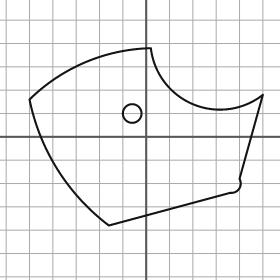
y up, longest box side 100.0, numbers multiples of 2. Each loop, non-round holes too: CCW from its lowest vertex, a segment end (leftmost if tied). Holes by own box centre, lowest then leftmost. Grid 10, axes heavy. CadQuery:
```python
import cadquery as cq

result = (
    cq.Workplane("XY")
    .moveTo(-16.0, -38.0)
    .lineTo(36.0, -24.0)
    .threePointArc((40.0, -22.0), (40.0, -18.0))
    .lineTo(50.0, 18.0)
    .threePointArc((20.0, 14.0), (2.0, 38.0))
    .threePointArc((-26.0, 32.0), (-50.0, 16.0))
    .threePointArc((-38.0, -14.0), (-16.0, -38.0))
    .close()
    .moveTo(-6.0, 10.0)
    .circle(4.0)
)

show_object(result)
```